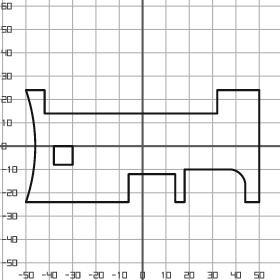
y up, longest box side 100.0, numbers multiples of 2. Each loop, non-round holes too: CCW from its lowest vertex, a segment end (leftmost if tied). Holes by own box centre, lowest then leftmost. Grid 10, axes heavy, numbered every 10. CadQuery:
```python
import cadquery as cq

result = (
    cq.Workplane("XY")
    .moveTo(-50.0, -24.0)
    .lineTo(-6.0, -24.0)
    .lineTo(-6.0, -12.0)
    .lineTo(14.0, -12.0)
    .lineTo(14.0, -24.0)
    .lineTo(18.0, -24.0)
    .lineTo(18.0, -10.0)
    .lineTo(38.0, -10.0)
    .threePointArc((42.0, -12.0), (44.0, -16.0))
    .lineTo(44.0, -24.0)
    .lineTo(50.0, -24.0)
    .lineTo(50.0, 24.0)
    .lineTo(32.0, 24.0)
    .lineTo(32.0, 14.0)
    .lineTo(-42.0, 14.0)
    .lineTo(-42.0, 24.0)
    .lineTo(-50.0, 24.0)
    .threePointArc((-46.0, 0.0), (-50.0, -24.0))
    .close()
    .moveTo(-38.0, -8.0)
    .lineTo(-30.0, -8.0)
    .lineTo(-30.0, 0.0)
    .lineTo(-38.0, 0.0)
    .close()
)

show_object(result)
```